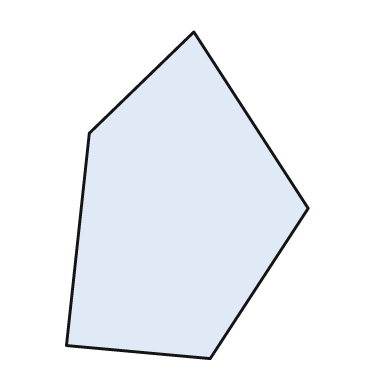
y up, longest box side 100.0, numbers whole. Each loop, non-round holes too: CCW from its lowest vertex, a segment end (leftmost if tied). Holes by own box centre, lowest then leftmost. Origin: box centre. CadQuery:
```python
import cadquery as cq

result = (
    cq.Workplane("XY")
    .moveTo(7.0, -50.0)
    .lineTo(37.0, -4.0)
    .lineTo(2.0, 50.0)
    .lineTo(-30.0, 19.0)
    .lineTo(-37.0, -46.0)
    .close()
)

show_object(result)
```